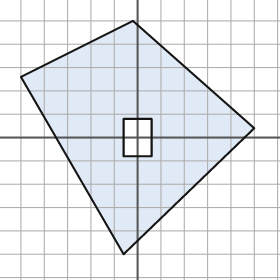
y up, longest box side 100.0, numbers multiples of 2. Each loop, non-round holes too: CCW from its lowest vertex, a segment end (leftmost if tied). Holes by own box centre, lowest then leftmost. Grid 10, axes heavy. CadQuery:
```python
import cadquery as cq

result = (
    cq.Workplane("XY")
    .moveTo(-6.0, -50.0)
    .lineTo(50.0, 4.0)
    .lineTo(-2.0, 50.0)
    .lineTo(-50.0, 26.0)
    .close()
    .moveTo(-6.0, -8.0)
    .lineTo(6.0, -8.0)
    .lineTo(6.0, 8.0)
    .lineTo(-6.0, 8.0)
    .close()
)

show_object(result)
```